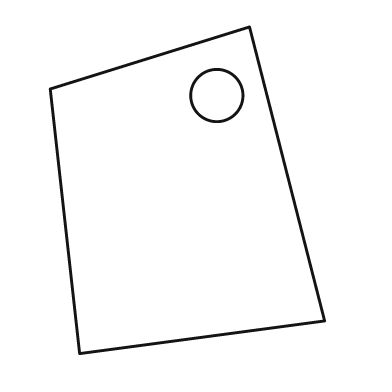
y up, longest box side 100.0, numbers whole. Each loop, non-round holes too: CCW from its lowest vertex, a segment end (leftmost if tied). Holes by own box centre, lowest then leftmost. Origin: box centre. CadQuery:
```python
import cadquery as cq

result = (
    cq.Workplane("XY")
    .moveTo(-33.0, -50.0)
    .lineTo(42.0, -40.0)
    .lineTo(19.0, 50.0)
    .lineTo(-42.0, 31.0)
    .close()
    .moveTo(9.0, 29.0)
    .circle(8.0)
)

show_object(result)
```